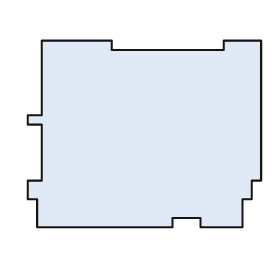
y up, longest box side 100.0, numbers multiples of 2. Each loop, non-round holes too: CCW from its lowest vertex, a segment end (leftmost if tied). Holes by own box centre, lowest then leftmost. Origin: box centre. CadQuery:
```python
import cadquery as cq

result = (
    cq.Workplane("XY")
    .moveTo(-46.0, -40.0)
    .lineTo(12.0, -40.0)
    .lineTo(12.0, -36.0)
    .lineTo(24.0, -36.0)
    .lineTo(24.0, -40.0)
    .lineTo(42.0, -40.0)
    .lineTo(42.0, -28.0)
    .lineTo(46.0, -28.0)
    .lineTo(46.0, -20.0)
    .lineTo(50.0, -20.0)
    .lineTo(50.0, 40.0)
    .lineTo(34.0, 40.0)
    .lineTo(34.0, 36.0)
    .lineTo(-14.0, 36.0)
    .lineTo(-14.0, 40.0)
    .lineTo(-44.0, 40.0)
    .lineTo(-44.0, 8.0)
    .lineTo(-50.0, 8.0)
    .lineTo(-50.0, 4.0)
    .lineTo(-44.0, 4.0)
    .lineTo(-44.0, -20.0)
    .lineTo(-50.0, -20.0)
    .lineTo(-50.0, -28.0)
    .lineTo(-46.0, -28.0)
    .close()
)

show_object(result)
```